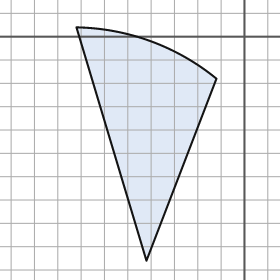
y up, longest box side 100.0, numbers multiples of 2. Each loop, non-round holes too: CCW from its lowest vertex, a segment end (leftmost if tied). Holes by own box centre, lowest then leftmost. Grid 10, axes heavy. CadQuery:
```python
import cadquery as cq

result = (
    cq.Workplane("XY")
    .moveTo(-42.0, -96.0)
    .lineTo(-12.0, -18.0)
    .threePointArc((-40.0, -2.0), (-72.0, 4.0))
    .close()
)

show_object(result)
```